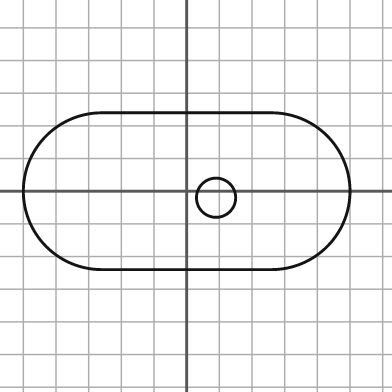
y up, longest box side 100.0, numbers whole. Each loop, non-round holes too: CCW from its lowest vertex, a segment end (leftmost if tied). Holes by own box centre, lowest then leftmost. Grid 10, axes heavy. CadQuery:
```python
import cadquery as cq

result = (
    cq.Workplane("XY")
    .moveTo(-26.0, -24.0)
    .lineTo(26.0, -24.0)
    .threePointArc((50.0, 0.0), (26.0, 24.0))
    .lineTo(-26.0, 24.0)
    .threePointArc((-50.0, 0.0), (-26.0, -24.0))
    .close()
    .moveTo(9.0, -2.0)
    .circle(6.0)
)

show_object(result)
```